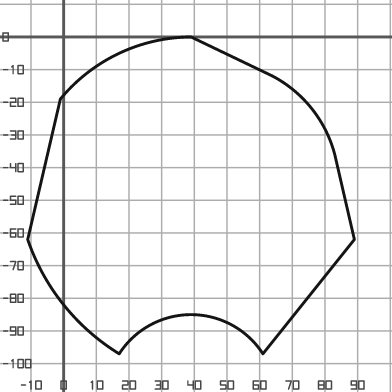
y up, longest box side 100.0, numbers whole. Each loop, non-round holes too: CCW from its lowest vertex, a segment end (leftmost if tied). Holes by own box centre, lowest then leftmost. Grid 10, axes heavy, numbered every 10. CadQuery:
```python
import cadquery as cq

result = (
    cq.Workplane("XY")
    .moveTo(17.0, -97.0)
    .threePointArc((39.0, -85.0), (61.0, -97.0))
    .lineTo(89.0, -62.0)
    .lineTo(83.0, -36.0)
    .threePointArc((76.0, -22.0), (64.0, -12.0))
    .lineTo(39.0, 0.0)
    .threePointArc((17.0, -5.0), (-1.0, -19.0))
    .lineTo(-11.0, -62.0)
    .threePointArc((0.0, -82.0), (17.0, -97.0))
    .close()
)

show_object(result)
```